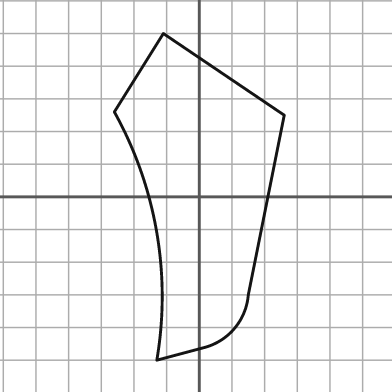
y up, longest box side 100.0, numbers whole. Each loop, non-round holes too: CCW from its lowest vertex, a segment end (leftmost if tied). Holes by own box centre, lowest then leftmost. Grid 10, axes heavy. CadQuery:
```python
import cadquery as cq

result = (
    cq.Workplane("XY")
    .moveTo(-13.0, -50.0)
    .lineTo(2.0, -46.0)
    .threePointArc((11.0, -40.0), (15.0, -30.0))
    .lineTo(26.0, 25.0)
    .lineTo(-11.0, 50.0)
    .lineTo(-26.0, 26.0)
    .threePointArc((-13.0, -11.0), (-13.0, -50.0))
    .close()
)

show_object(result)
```